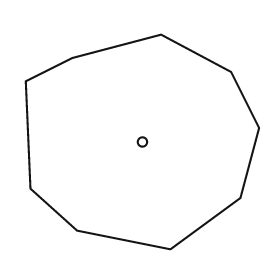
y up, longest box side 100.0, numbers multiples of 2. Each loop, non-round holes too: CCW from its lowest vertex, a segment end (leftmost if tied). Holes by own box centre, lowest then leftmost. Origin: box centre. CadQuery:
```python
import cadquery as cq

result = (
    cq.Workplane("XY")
    .moveTo(12.0, -46.0)
    .lineTo(42.0, -24.0)
    .lineTo(50.0, 6.0)
    .lineTo(38.0, 30.0)
    .lineTo(8.0, 46.0)
    .lineTo(-30.0, 36.0)
    .lineTo(-50.0, 26.0)
    .lineTo(-48.0, -20.0)
    .lineTo(-28.0, -38.0)
    .close()
    .moveTo(0.0, 0.0)
    .circle(2.0)
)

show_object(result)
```